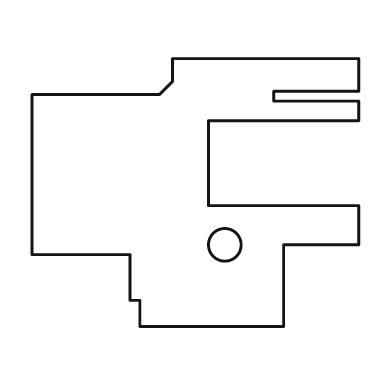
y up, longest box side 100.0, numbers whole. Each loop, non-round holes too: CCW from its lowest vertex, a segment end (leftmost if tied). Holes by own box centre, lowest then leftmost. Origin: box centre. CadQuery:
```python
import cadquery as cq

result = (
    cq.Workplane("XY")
    .moveTo(-17.0, -41.0)
    .lineTo(27.0, -41.0)
    .lineTo(27.0, -16.0)
    .lineTo(50.0, -16.0)
    .lineTo(50.0, -4.0)
    .lineTo(4.0, -4.0)
    .lineTo(4.0, 22.0)
    .lineTo(50.0, 22.0)
    .lineTo(50.0, 28.0)
    .lineTo(24.0, 28.0)
    .lineTo(24.0, 31.0)
    .lineTo(50.0, 31.0)
    .lineTo(50.0, 41.0)
    .lineTo(-7.0, 41.0)
    .lineTo(-7.0, 34.0)
    .lineTo(-11.0, 30.0)
    .lineTo(-50.0, 30.0)
    .lineTo(-50.0, -19.0)
    .lineTo(-20.0, -19.0)
    .lineTo(-20.0, -33.0)
    .lineTo(-17.0, -33.0)
    .close()
    .moveTo(9.0, -16.0)
    .circle(5.0)
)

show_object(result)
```